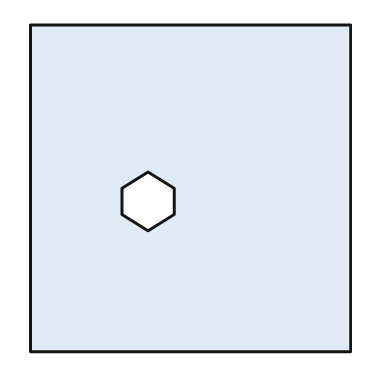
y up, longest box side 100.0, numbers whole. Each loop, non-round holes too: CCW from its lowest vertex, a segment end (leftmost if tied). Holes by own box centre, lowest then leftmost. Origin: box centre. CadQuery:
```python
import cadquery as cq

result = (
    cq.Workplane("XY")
    .moveTo(-49.0, -50.0)
    .lineTo(49.0, -50.0)
    .lineTo(49.0, 50.0)
    .lineTo(-49.0, 50.0)
    .close()
    .moveTo(-13.0, -13.0)
    .lineTo(-5.0, -8.0)
    .lineTo(-5.0, 0.0)
    .lineTo(-13.0, 5.0)
    .lineTo(-21.0, 0.0)
    .lineTo(-21.0, -8.0)
    .close()
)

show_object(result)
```